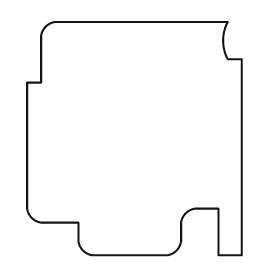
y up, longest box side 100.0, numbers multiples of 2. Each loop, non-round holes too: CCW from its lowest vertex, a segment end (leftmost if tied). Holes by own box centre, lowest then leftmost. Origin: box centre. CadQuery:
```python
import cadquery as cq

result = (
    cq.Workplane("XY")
    .moveTo(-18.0, -50.0)
    .lineTo(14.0, -50.0)
    .threePointArc((18.0, -48.0), (20.0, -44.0))
    .lineTo(20.0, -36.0)
    .threePointArc((22.0, -32.0), (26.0, -30.0))
    .lineTo(36.0, -30.0)
    .lineTo(36.0, -50.0)
    .lineTo(46.0, -50.0)
    .lineTo(46.0, 34.0)
    .lineTo(40.0, 34.0)
    .threePointArc((38.0, 42.0), (40.0, 50.0))
    .lineTo(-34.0, 50.0)
    .threePointArc((-38.0, 48.0), (-40.0, 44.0))
    .lineTo(-40.0, 24.0)
    .lineTo(-46.0, 24.0)
    .lineTo(-46.0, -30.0)
    .threePointArc((-44.0, -34.0), (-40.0, -36.0))
    .lineTo(-24.0, -36.0)
    .lineTo(-24.0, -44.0)
    .threePointArc((-22.0, -48.0), (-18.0, -50.0))
    .close()
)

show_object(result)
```